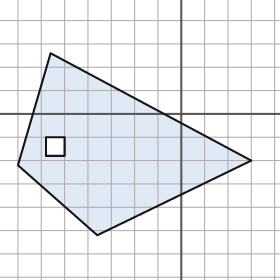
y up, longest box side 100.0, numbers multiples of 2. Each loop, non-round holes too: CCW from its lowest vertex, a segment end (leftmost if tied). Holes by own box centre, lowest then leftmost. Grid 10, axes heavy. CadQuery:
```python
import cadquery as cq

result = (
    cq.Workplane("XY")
    .moveTo(-36.0, -52.0)
    .lineTo(30.0, -20.0)
    .lineTo(-56.0, 26.0)
    .lineTo(-70.0, -22.0)
    .close()
    .moveTo(-58.0, -18.0)
    .lineTo(-50.0, -18.0)
    .lineTo(-50.0, -10.0)
    .lineTo(-58.0, -10.0)
    .close()
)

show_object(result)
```